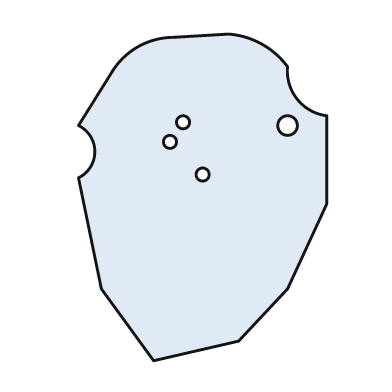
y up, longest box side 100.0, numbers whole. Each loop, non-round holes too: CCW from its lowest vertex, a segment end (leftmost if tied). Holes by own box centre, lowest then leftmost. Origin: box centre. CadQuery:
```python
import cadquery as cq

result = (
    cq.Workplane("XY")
    .moveTo(-15.0, -50.0)
    .lineTo(11.0, -44.0)
    .lineTo(26.0, -28.0)
    .lineTo(38.0, -2.0)
    .lineTo(38.0, 25.0)
    .threePointArc((29.0, 30.0), (26.0, 40.0))
    .threePointArc((18.0, 47.0), (8.0, 50.0))
    .lineTo(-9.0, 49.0)
    .threePointArc((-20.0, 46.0), (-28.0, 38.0))
    .lineTo(-38.0, 22.0)
    .threePointArc((-33.0, 14.0), (-38.0, 6.0))
    .lineTo(-31.0, -28.0)
    .close()
    .moveTo(0.0, 7.0)
    .circle(2.0)
    .moveTo(-10.0, 17.0)
    .circle(2.0)
    .moveTo(26.0, 22.0)
    .circle(3.0)
    .moveTo(-6.0, 23.0)
    .circle(2.0)
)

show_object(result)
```